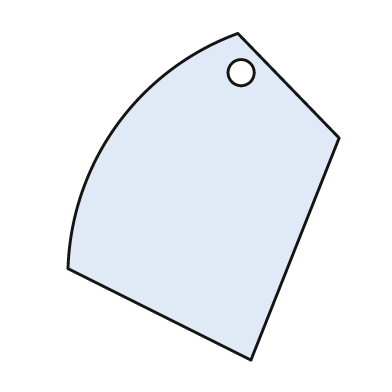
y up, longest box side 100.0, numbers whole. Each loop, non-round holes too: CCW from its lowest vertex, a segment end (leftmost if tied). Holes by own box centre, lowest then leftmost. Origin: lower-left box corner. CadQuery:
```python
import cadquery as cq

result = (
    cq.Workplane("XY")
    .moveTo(56.0, 0.0)
    .lineTo(83.0, 68.0)
    .lineTo(52.0, 100.0)
    .threePointArc((15.0, 72.0), (0.0, 28.0))
    .close()
    .moveTo(53.0, 88.0)
    .circle(4.0)
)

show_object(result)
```